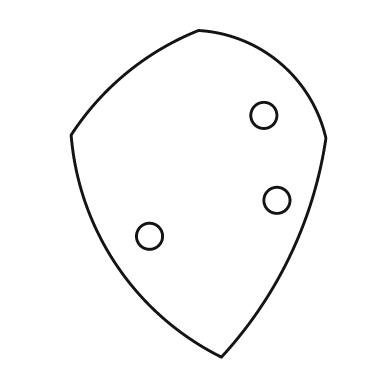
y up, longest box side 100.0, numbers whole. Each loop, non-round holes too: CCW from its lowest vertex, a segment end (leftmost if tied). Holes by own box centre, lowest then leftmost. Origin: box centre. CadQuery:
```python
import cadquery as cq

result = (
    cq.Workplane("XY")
    .moveTo(7.0, -50.0)
    .threePointArc((28.0, -19.0), (39.0, 17.0))
    .threePointArc((25.0, 40.0), (0.0, 50.0))
    .threePointArc((-22.0, 37.0), (-39.0, 18.0))
    .threePointArc((-25.0, -22.0), (7.0, -50.0))
    .close()
    .moveTo(-15.0, -13.0)
    .circle(4.0)
    .moveTo(24.0, -2.0)
    .circle(4.0)
    .moveTo(20.0, 24.0)
    .circle(4.0)
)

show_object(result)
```